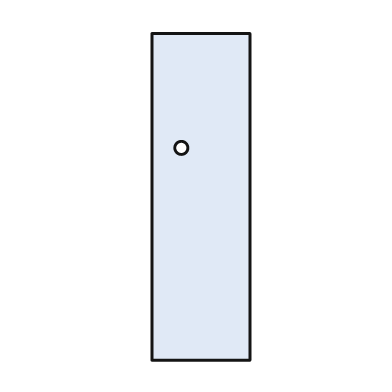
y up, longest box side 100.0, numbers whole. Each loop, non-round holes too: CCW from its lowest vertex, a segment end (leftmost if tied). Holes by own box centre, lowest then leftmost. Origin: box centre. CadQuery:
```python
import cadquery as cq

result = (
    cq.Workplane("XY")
    .moveTo(-15.0, -50.0)
    .lineTo(15.0, -50.0)
    .lineTo(15.0, 50.0)
    .lineTo(-15.0, 50.0)
    .close()
    .moveTo(-6.0, 15.0)
    .circle(2.0)
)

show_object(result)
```